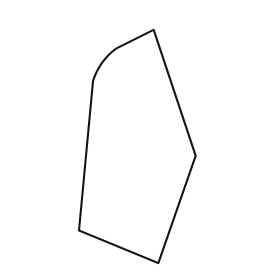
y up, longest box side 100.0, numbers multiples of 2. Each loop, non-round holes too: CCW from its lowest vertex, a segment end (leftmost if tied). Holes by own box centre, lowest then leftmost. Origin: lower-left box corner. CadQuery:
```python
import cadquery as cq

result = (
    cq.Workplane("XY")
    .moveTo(34.0, 0.0)
    .lineTo(50.0, 46.0)
    .lineTo(32.0, 100.0)
    .lineTo(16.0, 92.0)
    .threePointArc((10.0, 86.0), (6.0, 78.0))
    .lineTo(0.0, 14.0)
    .close()
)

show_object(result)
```